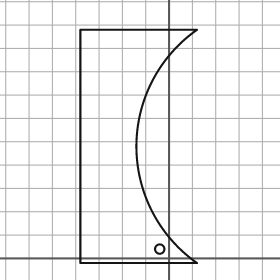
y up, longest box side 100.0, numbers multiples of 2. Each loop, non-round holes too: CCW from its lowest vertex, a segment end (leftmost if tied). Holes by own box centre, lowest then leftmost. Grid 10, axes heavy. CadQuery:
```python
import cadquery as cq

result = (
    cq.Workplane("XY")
    .moveTo(-38.0, -2.0)
    .lineTo(12.0, -2.0)
    .threePointArc((-14.0, 48.0), (12.0, 98.0))
    .lineTo(-38.0, 98.0)
    .close()
    .moveTo(-4.0, 4.0)
    .circle(2.0)
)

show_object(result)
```